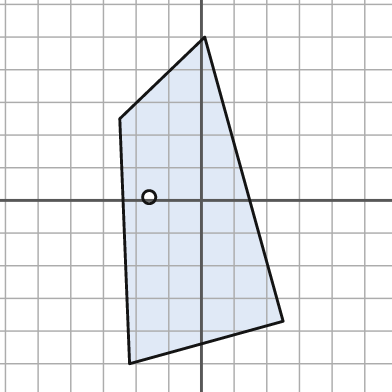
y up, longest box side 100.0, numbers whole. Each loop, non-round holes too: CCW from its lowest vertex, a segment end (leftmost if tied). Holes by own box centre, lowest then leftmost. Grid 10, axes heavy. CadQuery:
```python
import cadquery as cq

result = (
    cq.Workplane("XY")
    .moveTo(-22.0, -50.0)
    .lineTo(25.0, -37.0)
    .lineTo(1.0, 50.0)
    .lineTo(-25.0, 25.0)
    .close()
    .moveTo(-16.0, 1.0)
    .circle(2.0)
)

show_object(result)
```